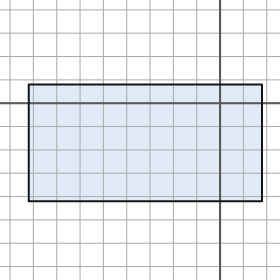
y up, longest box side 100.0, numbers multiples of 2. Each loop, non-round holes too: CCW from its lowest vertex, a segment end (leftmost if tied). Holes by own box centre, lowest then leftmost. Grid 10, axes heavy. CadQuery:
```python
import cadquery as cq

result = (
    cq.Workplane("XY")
    .moveTo(-82.0, -42.0)
    .lineTo(18.0, -42.0)
    .lineTo(18.0, 8.0)
    .lineTo(-82.0, 8.0)
    .close()
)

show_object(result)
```